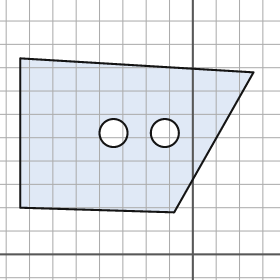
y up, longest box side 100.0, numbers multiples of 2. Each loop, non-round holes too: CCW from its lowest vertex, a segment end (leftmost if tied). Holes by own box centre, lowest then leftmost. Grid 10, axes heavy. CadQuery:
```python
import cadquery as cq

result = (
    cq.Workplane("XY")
    .moveTo(-8.0, 18.0)
    .lineTo(26.0, 78.0)
    .lineTo(-74.0, 84.0)
    .lineTo(-74.0, 20.0)
    .close()
    .moveTo(-34.0, 52.0)
    .circle(6.0)
    .moveTo(-12.0, 52.0)
    .circle(6.0)
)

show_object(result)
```